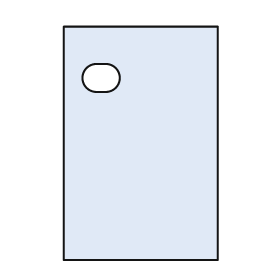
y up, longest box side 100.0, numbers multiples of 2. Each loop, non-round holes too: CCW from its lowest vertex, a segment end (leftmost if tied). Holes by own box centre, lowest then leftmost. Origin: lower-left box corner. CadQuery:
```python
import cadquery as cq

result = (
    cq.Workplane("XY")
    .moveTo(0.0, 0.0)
    .lineTo(66.0, 0.0)
    .lineTo(66.0, 100.0)
    .lineTo(0.0, 100.0)
    .close()
    .moveTo(14.0, 72.0)
    .lineTo(18.0, 72.0)
    .threePointArc((24.0, 78.0), (18.0, 84.0))
    .lineTo(14.0, 84.0)
    .threePointArc((8.0, 78.0), (14.0, 72.0))
    .close()
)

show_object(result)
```